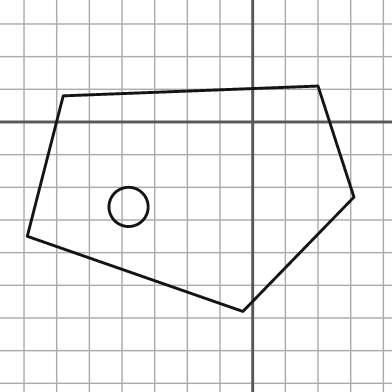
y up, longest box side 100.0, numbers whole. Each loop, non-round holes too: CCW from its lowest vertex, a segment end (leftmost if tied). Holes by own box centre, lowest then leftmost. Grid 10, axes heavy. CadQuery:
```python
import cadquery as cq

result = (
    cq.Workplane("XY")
    .moveTo(-3.0, -58.0)
    .lineTo(31.0, -23.0)
    .lineTo(20.0, 11.0)
    .lineTo(-58.0, 8.0)
    .lineTo(-69.0, -35.0)
    .close()
    .moveTo(-38.0, -26.0)
    .circle(6.0)
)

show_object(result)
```